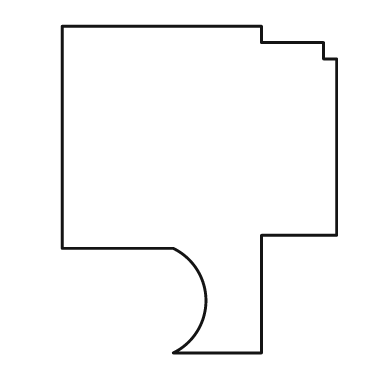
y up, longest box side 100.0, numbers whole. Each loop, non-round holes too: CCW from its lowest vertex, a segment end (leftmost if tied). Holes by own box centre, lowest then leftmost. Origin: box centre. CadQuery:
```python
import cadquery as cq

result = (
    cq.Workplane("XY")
    .moveTo(-8.0, -50.0)
    .lineTo(19.0, -50.0)
    .lineTo(19.0, -14.0)
    .lineTo(42.0, -14.0)
    .lineTo(42.0, 40.0)
    .lineTo(38.0, 40.0)
    .lineTo(38.0, 45.0)
    .lineTo(19.0, 45.0)
    .lineTo(19.0, 50.0)
    .lineTo(-42.0, 50.0)
    .lineTo(-42.0, -18.0)
    .lineTo(-8.0, -18.0)
    .threePointArc((2.0, -34.0), (-8.0, -50.0))
    .close()
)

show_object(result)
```